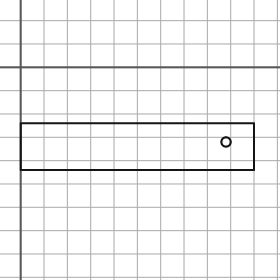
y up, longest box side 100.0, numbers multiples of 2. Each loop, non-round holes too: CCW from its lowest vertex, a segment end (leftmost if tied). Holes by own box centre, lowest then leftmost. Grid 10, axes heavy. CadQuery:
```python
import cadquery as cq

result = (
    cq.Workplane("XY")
    .moveTo(0.0, -44.0)
    .lineTo(100.0, -44.0)
    .lineTo(100.0, -24.0)
    .lineTo(0.0, -24.0)
    .close()
    .moveTo(88.0, -32.0)
    .circle(2.0)
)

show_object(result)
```